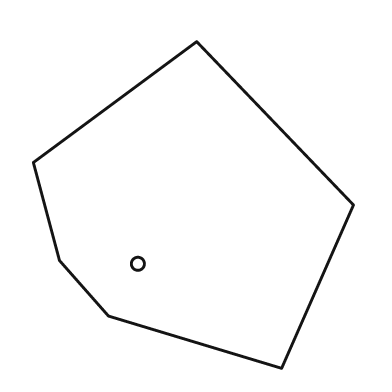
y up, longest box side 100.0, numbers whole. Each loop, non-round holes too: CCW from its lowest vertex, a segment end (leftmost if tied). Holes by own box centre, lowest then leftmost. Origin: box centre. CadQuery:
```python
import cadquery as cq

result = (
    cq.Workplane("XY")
    .moveTo(27.0, -50.0)
    .lineTo(49.0, 0.0)
    .lineTo(1.0, 50.0)
    .lineTo(-49.0, 13.0)
    .lineTo(-41.0, -17.0)
    .lineTo(-26.0, -34.0)
    .close()
    .moveTo(-17.0, -18.0)
    .circle(2.0)
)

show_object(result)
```